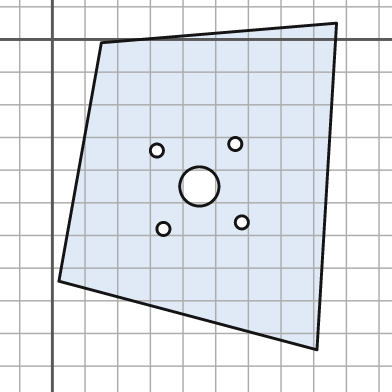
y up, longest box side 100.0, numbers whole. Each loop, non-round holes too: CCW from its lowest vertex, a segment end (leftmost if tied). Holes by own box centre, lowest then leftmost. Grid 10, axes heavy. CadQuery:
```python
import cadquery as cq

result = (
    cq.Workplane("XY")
    .moveTo(81.0, -95.0)
    .lineTo(87.0, 5.0)
    .lineTo(15.0, -1.0)
    .lineTo(2.0, -74.0)
    .close()
    .moveTo(34.0, -58.0)
    .circle(2.0)
    .moveTo(58.0, -56.0)
    .circle(2.0)
    .moveTo(45.0, -45.0)
    .circle(6.0)
    .moveTo(32.0, -34.0)
    .circle(2.0)
    .moveTo(56.0, -32.0)
    .circle(2.0)
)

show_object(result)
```